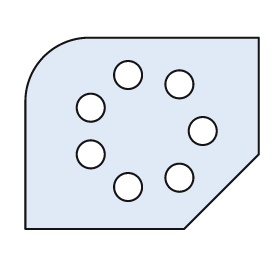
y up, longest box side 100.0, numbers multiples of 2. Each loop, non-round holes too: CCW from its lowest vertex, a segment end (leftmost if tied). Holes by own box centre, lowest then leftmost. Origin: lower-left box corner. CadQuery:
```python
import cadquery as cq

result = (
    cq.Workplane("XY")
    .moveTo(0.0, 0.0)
    .lineTo(68.0, 0.0)
    .lineTo(100.0, 32.0)
    .lineTo(100.0, 82.0)
    .lineTo(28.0, 82.0)
    .threePointArc((8.0, 74.0), (0.0, 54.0))
    .close()
    .moveTo(44.0, 18.0)
    .circle(6.0)
    .moveTo(66.0, 22.0)
    .circle(6.0)
    .moveTo(28.0, 32.0)
    .circle(6.0)
    .moveTo(76.0, 42.0)
    .circle(6.0)
    .moveTo(28.0, 52.0)
    .circle(6.0)
    .moveTo(66.0, 62.0)
    .circle(6.0)
    .moveTo(44.0, 66.0)
    .circle(6.0)
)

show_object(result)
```